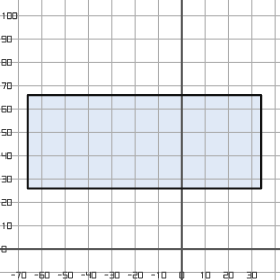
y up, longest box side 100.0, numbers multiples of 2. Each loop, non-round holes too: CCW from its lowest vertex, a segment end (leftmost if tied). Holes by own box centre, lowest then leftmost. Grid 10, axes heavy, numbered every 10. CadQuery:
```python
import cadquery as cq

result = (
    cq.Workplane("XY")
    .moveTo(-66.0, 26.0)
    .lineTo(34.0, 26.0)
    .lineTo(34.0, 66.0)
    .lineTo(-66.0, 66.0)
    .close()
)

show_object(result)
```